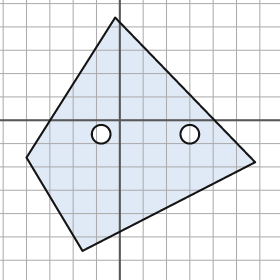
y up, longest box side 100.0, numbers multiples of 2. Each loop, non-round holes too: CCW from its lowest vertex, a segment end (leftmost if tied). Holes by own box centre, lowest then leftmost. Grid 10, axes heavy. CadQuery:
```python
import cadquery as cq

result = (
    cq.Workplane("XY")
    .moveTo(-16.0, -56.0)
    .lineTo(58.0, -18.0)
    .lineTo(-2.0, 44.0)
    .lineTo(-40.0, -16.0)
    .close()
    .moveTo(-8.0, -6.0)
    .circle(4.0)
    .moveTo(30.0, -6.0)
    .circle(4.0)
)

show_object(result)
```